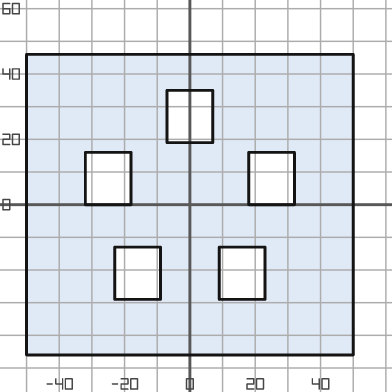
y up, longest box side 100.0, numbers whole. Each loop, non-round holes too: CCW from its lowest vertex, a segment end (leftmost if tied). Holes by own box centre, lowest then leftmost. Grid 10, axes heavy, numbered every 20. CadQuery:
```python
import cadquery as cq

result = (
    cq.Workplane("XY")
    .moveTo(-50.0, -46.0)
    .lineTo(50.0, -46.0)
    .lineTo(50.0, 46.0)
    .lineTo(-50.0, 46.0)
    .close()
    .moveTo(-23.0, -29.0)
    .lineTo(-9.0, -29.0)
    .lineTo(-9.0, -13.0)
    .lineTo(-23.0, -13.0)
    .close()
    .moveTo(9.0, -29.0)
    .lineTo(23.0, -29.0)
    .lineTo(23.0, -13.0)
    .lineTo(9.0, -13.0)
    .close()
    .moveTo(-32.0, 0.0)
    .lineTo(-18.0, 0.0)
    .lineTo(-18.0, 16.0)
    .lineTo(-32.0, 16.0)
    .close()
    .moveTo(18.0, 0.0)
    .lineTo(32.0, 0.0)
    .lineTo(32.0, 16.0)
    .lineTo(18.0, 16.0)
    .close()
    .moveTo(-7.0, 19.0)
    .lineTo(7.0, 19.0)
    .lineTo(7.0, 35.0)
    .lineTo(-7.0, 35.0)
    .close()
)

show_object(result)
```